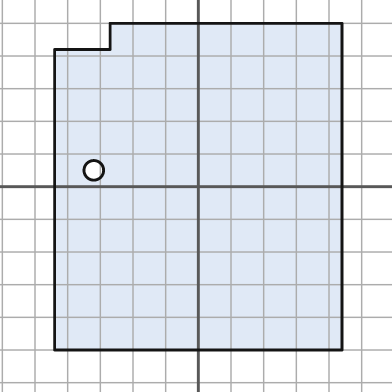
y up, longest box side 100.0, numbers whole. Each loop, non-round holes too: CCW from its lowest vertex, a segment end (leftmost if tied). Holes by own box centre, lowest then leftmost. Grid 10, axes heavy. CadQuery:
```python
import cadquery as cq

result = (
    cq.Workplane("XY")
    .moveTo(-44.0, -50.0)
    .lineTo(44.0, -50.0)
    .lineTo(44.0, 50.0)
    .lineTo(-27.0, 50.0)
    .lineTo(-27.0, 42.0)
    .lineTo(-44.0, 42.0)
    .close()
    .moveTo(-32.0, 5.0)
    .circle(3.0)
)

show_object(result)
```